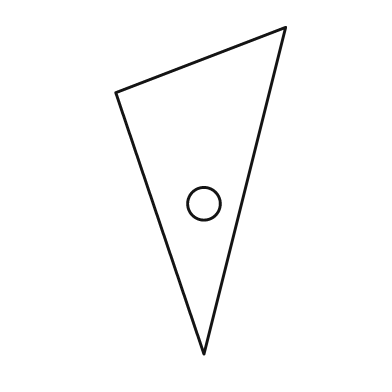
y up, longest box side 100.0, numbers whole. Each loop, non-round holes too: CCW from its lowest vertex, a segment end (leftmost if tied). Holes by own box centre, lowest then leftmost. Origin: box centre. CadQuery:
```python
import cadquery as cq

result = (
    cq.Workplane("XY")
    .moveTo(1.0, -50.0)
    .lineTo(26.0, 50.0)
    .lineTo(-26.0, 30.0)
    .close()
    .moveTo(1.0, -4.0)
    .circle(5.0)
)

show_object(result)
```